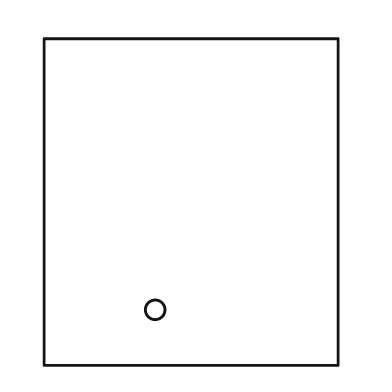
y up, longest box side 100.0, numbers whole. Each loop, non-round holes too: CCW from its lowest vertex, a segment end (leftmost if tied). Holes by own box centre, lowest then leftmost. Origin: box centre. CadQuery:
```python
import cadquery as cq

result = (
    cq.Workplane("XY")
    .moveTo(-45.0, -50.0)
    .lineTo(45.0, -50.0)
    .lineTo(45.0, 50.0)
    .lineTo(-45.0, 50.0)
    .close()
    .moveTo(-11.0, -33.0)
    .circle(3.0)
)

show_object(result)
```